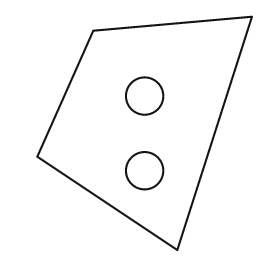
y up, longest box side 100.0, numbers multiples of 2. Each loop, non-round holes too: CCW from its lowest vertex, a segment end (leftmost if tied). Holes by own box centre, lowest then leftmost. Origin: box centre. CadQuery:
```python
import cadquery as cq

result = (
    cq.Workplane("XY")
    .moveTo(14.0, -50.0)
    .lineTo(46.0, 50.0)
    .lineTo(-22.0, 44.0)
    .lineTo(-46.0, -10.0)
    .close()
    .moveTo(0.0, -16.0)
    .circle(8.0)
    .moveTo(0.0, 16.0)
    .circle(8.0)
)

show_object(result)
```